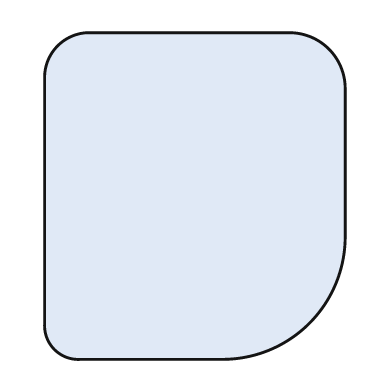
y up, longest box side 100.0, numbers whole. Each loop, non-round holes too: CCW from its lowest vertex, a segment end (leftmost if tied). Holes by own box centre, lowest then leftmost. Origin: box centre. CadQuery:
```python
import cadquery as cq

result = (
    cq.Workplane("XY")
    .moveTo(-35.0, -50.0)
    .lineTo(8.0, -50.0)
    .threePointArc((35.0, -39.0), (46.0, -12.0))
    .lineTo(46.0, 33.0)
    .threePointArc((41.0, 45.0), (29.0, 50.0))
    .lineTo(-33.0, 50.0)
    .threePointArc((-42.0, 46.0), (-46.0, 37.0))
    .lineTo(-46.0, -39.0)
    .threePointArc((-43.0, -47.0), (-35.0, -50.0))
    .close()
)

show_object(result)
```